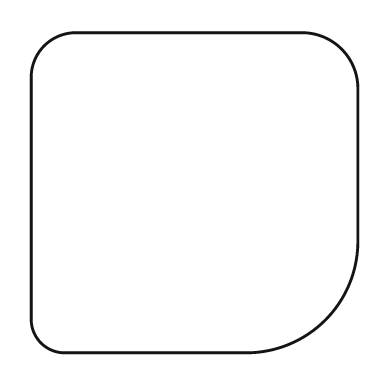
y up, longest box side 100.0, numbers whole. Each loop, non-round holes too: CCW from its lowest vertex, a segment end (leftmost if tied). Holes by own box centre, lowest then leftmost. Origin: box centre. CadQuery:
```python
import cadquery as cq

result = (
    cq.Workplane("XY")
    .moveTo(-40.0, -49.0)
    .lineTo(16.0, -49.0)
    .threePointArc((40.0, -39.0), (50.0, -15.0))
    .lineTo(50.0, 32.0)
    .threePointArc((45.0, 44.0), (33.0, 49.0))
    .lineTo(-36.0, 49.0)
    .threePointArc((-46.0, 45.0), (-50.0, 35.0))
    .lineTo(-50.0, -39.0)
    .threePointArc((-47.0, -46.0), (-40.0, -49.0))
    .close()
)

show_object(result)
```